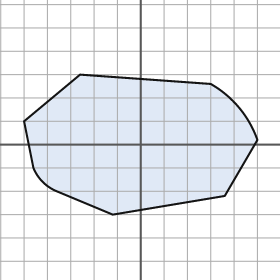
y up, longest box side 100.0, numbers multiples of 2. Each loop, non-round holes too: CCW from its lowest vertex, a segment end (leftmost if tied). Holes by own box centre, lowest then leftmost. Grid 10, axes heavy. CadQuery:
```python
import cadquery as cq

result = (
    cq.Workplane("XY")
    .moveTo(-12.0, -30.0)
    .lineTo(36.0, -22.0)
    .lineTo(50.0, 2.0)
    .threePointArc((42.0, 16.0), (30.0, 26.0))
    .lineTo(-26.0, 30.0)
    .lineTo(-50.0, 10.0)
    .lineTo(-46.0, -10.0)
    .threePointArc((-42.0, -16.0), (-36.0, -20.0))
    .close()
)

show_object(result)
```